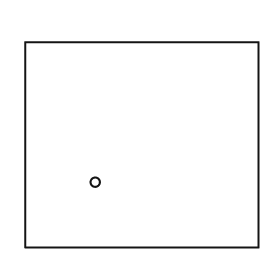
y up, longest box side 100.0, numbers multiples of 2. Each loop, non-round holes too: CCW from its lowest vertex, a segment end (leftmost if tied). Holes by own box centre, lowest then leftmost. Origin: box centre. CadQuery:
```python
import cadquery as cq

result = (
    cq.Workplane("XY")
    .moveTo(-50.0, -44.0)
    .lineTo(50.0, -44.0)
    .lineTo(50.0, 44.0)
    .lineTo(-50.0, 44.0)
    .close()
    .moveTo(-20.0, -16.0)
    .circle(2.0)
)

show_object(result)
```